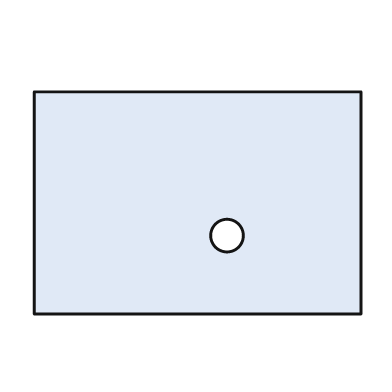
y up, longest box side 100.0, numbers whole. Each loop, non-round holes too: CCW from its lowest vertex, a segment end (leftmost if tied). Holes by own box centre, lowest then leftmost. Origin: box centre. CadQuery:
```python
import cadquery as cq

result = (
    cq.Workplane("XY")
    .moveTo(-50.0, -34.0)
    .lineTo(50.0, -34.0)
    .lineTo(50.0, 34.0)
    .lineTo(-50.0, 34.0)
    .close()
    .moveTo(9.0, -10.0)
    .circle(5.0)
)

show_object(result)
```